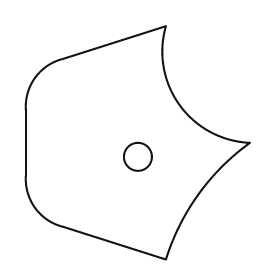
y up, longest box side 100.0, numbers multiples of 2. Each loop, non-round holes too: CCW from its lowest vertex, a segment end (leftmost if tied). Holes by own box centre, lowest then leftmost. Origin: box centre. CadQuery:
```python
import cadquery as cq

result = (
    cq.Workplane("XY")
    .moveTo(12.0, -50.0)
    .threePointArc((26.0, -22.0), (48.0, 0.0))
    .threePointArc((18.0, 16.0), (12.0, 50.0))
    .lineTo(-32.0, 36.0)
    .threePointArc((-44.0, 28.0), (-48.0, 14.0))
    .lineTo(-48.0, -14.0)
    .threePointArc((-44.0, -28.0), (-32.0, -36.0))
    .close()
    .moveTo(0.0, -6.0)
    .circle(6.0)
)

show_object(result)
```